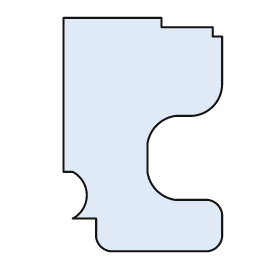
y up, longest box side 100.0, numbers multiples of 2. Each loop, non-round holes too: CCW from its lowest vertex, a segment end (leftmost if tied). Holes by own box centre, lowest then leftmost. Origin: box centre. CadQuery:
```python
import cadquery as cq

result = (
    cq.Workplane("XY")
    .moveTo(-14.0, -50.0)
    .lineTo(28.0, -50.0)
    .threePointArc((32.0, -48.0), (34.0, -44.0))
    .lineTo(34.0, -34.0)
    .threePointArc((32.0, -30.0), (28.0, -28.0))
    .lineTo(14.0, -28.0)
    .threePointArc((6.0, -24.0), (2.0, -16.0))
    .lineTo(2.0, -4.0)
    .threePointArc((6.0, 4.0), (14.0, 8.0))
    .lineTo(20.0, 8.0)
    .threePointArc((30.0, 12.0), (34.0, 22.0))
    .lineTo(34.0, 42.0)
    .lineTo(30.0, 42.0)
    .lineTo(30.0, 46.0)
    .lineTo(8.0, 46.0)
    .lineTo(8.0, 50.0)
    .lineTo(-34.0, 50.0)
    .lineTo(-34.0, -16.0)
    .lineTo(-30.0, -16.0)
    .threePointArc((-24.0, -26.0), (-30.0, -36.0))
    .lineTo(-20.0, -36.0)
    .lineTo(-20.0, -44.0)
    .threePointArc((-18.0, -48.0), (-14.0, -50.0))
    .close()
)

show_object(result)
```